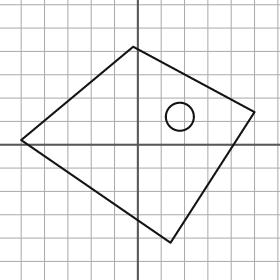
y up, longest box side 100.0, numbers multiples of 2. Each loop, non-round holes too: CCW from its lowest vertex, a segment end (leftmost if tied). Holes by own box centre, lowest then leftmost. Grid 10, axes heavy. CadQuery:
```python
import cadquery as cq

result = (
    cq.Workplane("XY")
    .moveTo(14.0, -42.0)
    .lineTo(50.0, 14.0)
    .lineTo(-2.0, 42.0)
    .lineTo(-50.0, 2.0)
    .close()
    .moveTo(18.0, 12.0)
    .circle(6.0)
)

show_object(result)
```